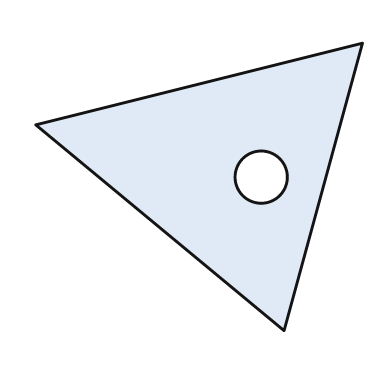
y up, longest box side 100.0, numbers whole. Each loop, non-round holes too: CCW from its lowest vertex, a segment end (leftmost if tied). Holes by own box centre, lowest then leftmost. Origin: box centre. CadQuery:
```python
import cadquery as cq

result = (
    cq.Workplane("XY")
    .moveTo(26.0, -44.0)
    .lineTo(50.0, 44.0)
    .lineTo(-50.0, 19.0)
    .close()
    .moveTo(19.0, 3.0)
    .circle(8.0)
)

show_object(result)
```